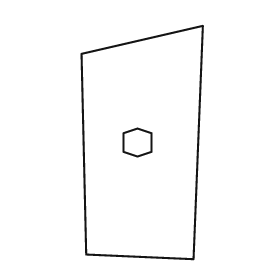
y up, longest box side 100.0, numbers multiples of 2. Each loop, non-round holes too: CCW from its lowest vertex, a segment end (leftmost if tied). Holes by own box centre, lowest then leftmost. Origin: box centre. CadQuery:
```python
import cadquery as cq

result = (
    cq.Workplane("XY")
    .moveTo(22.0, -50.0)
    .lineTo(26.0, 50.0)
    .lineTo(-26.0, 38.0)
    .lineTo(-24.0, -48.0)
    .close()
    .moveTo(-2.0, -6.0)
    .lineTo(4.0, -4.0)
    .lineTo(4.0, 4.0)
    .lineTo(-2.0, 6.0)
    .lineTo(-8.0, 4.0)
    .lineTo(-8.0, -4.0)
    .close()
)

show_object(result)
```